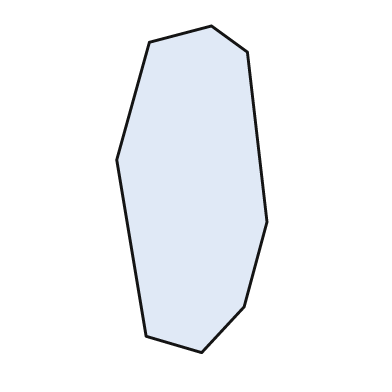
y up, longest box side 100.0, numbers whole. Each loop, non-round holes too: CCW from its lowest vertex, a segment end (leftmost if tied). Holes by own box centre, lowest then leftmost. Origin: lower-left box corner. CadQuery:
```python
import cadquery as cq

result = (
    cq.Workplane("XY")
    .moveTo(26.0, 0.0)
    .lineTo(39.0, 14.0)
    .lineTo(46.0, 40.0)
    .lineTo(40.0, 92.0)
    .lineTo(29.0, 100.0)
    .lineTo(10.0, 95.0)
    .lineTo(0.0, 59.0)
    .lineTo(9.0, 5.0)
    .close()
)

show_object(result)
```